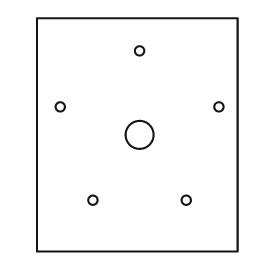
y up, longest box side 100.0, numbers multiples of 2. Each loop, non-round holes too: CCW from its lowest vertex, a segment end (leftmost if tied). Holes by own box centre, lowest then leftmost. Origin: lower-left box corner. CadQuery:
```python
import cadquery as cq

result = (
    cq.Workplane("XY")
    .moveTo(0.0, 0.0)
    .lineTo(86.0, 0.0)
    .lineTo(86.0, 100.0)
    .lineTo(0.0, 100.0)
    .close()
    .moveTo(24.0, 22.0)
    .circle(2.0)
    .moveTo(64.0, 22.0)
    .circle(2.0)
    .moveTo(44.0, 50.0)
    .circle(6.0)
    .moveTo(10.0, 62.0)
    .circle(2.0)
    .moveTo(78.0, 62.0)
    .circle(2.0)
    .moveTo(44.0, 86.0)
    .circle(2.0)
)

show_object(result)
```